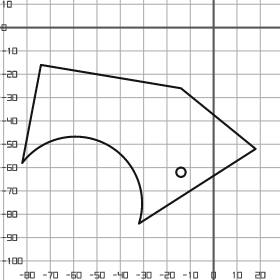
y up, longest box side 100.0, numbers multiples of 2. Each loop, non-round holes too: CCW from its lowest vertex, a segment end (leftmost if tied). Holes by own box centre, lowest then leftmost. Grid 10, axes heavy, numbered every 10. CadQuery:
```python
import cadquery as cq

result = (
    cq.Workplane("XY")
    .moveTo(-32.0, -84.0)
    .lineTo(18.0, -52.0)
    .lineTo(-14.0, -26.0)
    .lineTo(-74.0, -16.0)
    .lineTo(-82.0, -58.0)
    .threePointArc((-46.0, -50.0), (-32.0, -84.0))
    .close()
    .moveTo(-14.0, -62.0)
    .circle(2.0)
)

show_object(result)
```